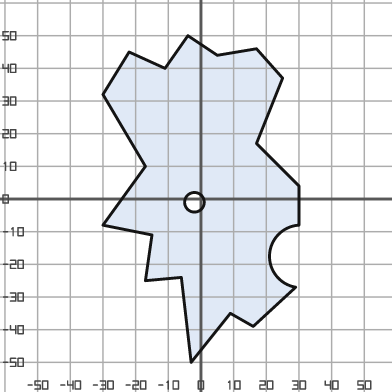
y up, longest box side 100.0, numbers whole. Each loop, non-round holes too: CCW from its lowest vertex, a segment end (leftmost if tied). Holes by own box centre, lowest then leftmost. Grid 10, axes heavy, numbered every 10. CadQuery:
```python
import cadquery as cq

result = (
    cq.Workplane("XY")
    .moveTo(-3.0, -50.0)
    .lineTo(9.0, -35.0)
    .lineTo(16.0, -39.0)
    .lineTo(29.0, -27.0)
    .threePointArc((21.0, -17.0), (30.0, -8.0))
    .lineTo(30.0, 4.0)
    .lineTo(17.0, 17.0)
    .lineTo(25.0, 37.0)
    .lineTo(17.0, 46.0)
    .lineTo(5.0, 44.0)
    .lineTo(-4.0, 50.0)
    .lineTo(-11.0, 40.0)
    .lineTo(-22.0, 45.0)
    .lineTo(-30.0, 32.0)
    .lineTo(-17.0, 10.0)
    .lineTo(-30.0, -8.0)
    .lineTo(-15.0, -11.0)
    .lineTo(-17.0, -25.0)
    .lineTo(-6.0, -24.0)
    .close()
    .moveTo(-2.0, -1.0)
    .circle(3.0)
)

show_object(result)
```